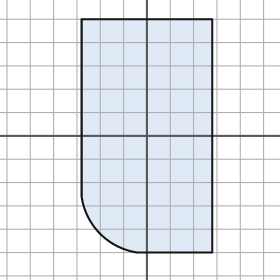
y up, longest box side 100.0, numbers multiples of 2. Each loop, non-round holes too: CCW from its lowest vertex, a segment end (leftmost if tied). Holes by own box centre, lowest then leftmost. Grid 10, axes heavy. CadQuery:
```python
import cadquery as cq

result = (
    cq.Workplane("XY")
    .moveTo(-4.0, -50.0)
    .lineTo(28.0, -50.0)
    .lineTo(28.0, 50.0)
    .lineTo(-28.0, 50.0)
    .lineTo(-28.0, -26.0)
    .threePointArc((-20.0, -42.0), (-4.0, -50.0))
    .close()
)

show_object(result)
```